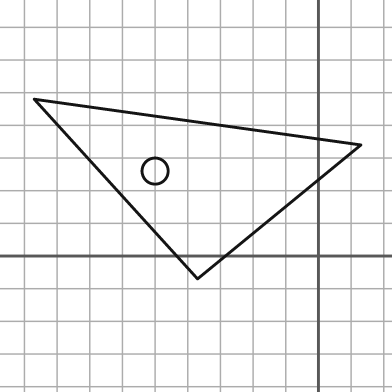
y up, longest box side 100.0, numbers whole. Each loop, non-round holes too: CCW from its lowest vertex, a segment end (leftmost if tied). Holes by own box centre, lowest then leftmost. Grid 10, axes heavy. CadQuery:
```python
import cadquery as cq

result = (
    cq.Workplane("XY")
    .moveTo(-37.0, -7.0)
    .lineTo(13.0, 34.0)
    .lineTo(-87.0, 48.0)
    .close()
    .moveTo(-50.0, 26.0)
    .circle(4.0)
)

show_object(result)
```